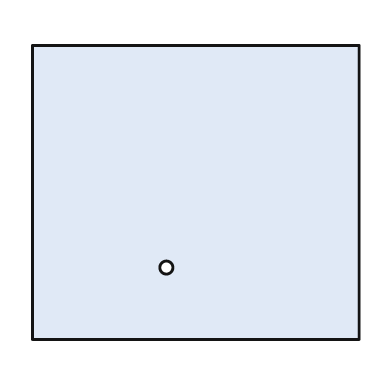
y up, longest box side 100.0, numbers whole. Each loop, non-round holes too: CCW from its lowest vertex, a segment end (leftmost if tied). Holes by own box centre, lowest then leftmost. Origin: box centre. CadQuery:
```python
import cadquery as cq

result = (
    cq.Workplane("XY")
    .moveTo(-50.0, -45.0)
    .lineTo(50.0, -45.0)
    .lineTo(50.0, 45.0)
    .lineTo(-50.0, 45.0)
    .close()
    .moveTo(-9.0, -23.0)
    .circle(2.0)
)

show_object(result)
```